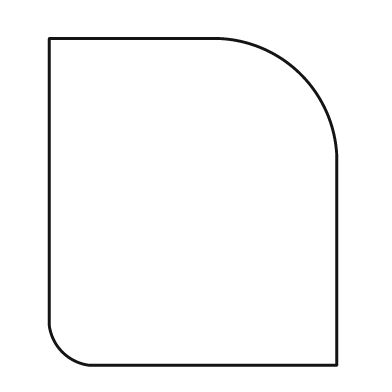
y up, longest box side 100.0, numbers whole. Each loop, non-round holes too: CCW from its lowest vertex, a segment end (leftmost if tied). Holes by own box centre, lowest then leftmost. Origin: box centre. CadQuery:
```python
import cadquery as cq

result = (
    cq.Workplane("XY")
    .moveTo(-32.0, -50.0)
    .lineTo(44.0, -50.0)
    .lineTo(44.0, 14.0)
    .threePointArc((33.0, 39.0), (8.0, 50.0))
    .lineTo(-44.0, 50.0)
    .lineTo(-44.0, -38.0)
    .threePointArc((-40.0, -46.0), (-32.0, -50.0))
    .close()
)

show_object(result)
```